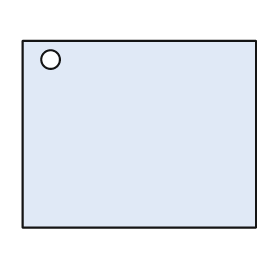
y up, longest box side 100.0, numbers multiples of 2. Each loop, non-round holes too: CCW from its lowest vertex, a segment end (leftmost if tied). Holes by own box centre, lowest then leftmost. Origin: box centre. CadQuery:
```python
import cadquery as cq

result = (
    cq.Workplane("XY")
    .moveTo(-50.0, -40.0)
    .lineTo(50.0, -40.0)
    .lineTo(50.0, 40.0)
    .lineTo(-50.0, 40.0)
    .close()
    .moveTo(-38.0, 32.0)
    .circle(4.0)
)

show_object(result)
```